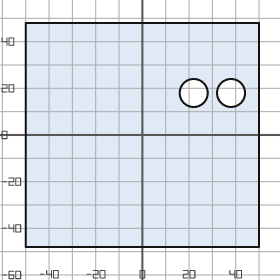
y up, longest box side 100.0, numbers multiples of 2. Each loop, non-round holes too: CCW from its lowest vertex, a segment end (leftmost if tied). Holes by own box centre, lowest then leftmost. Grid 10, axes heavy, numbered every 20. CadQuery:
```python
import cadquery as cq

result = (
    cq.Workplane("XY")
    .moveTo(-50.0, -48.0)
    .lineTo(50.0, -48.0)
    .lineTo(50.0, 48.0)
    .lineTo(-50.0, 48.0)
    .close()
    .moveTo(22.0, 18.0)
    .circle(6.0)
    .moveTo(38.0, 18.0)
    .circle(6.0)
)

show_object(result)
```